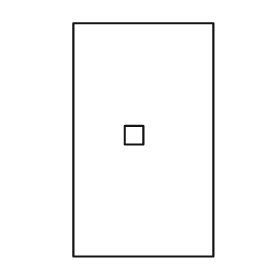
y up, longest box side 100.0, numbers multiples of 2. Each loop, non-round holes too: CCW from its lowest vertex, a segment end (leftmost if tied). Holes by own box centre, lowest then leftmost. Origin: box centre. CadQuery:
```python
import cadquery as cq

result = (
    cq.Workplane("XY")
    .moveTo(-30.0, -50.0)
    .lineTo(30.0, -50.0)
    .lineTo(30.0, 50.0)
    .lineTo(-30.0, 50.0)
    .close()
    .moveTo(-8.0, -2.0)
    .lineTo(0.0, -2.0)
    .lineTo(0.0, 6.0)
    .lineTo(-8.0, 6.0)
    .close()
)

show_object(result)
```